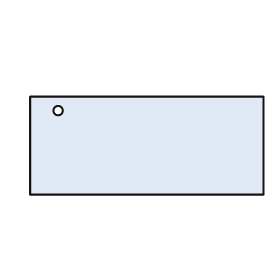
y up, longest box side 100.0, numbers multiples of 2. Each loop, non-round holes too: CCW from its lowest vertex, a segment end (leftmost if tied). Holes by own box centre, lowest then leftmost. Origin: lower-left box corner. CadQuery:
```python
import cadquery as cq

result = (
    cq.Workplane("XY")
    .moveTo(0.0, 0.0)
    .lineTo(100.0, 0.0)
    .lineTo(100.0, 42.0)
    .lineTo(0.0, 42.0)
    .close()
    .moveTo(12.0, 36.0)
    .circle(2.0)
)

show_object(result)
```